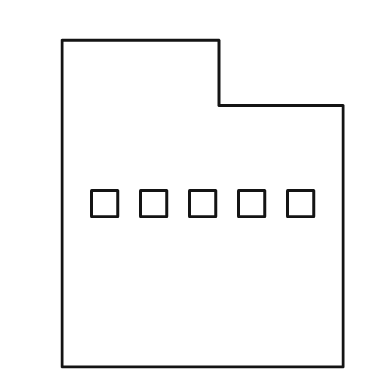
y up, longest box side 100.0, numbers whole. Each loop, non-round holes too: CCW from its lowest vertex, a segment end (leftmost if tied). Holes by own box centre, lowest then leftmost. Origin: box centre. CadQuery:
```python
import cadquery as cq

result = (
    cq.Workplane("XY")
    .moveTo(-43.0, -50.0)
    .lineTo(43.0, -50.0)
    .lineTo(43.0, 30.0)
    .lineTo(5.0, 30.0)
    .lineTo(5.0, 50.0)
    .lineTo(-43.0, 50.0)
    .close()
    .moveTo(-34.0, -4.0)
    .lineTo(-26.0, -4.0)
    .lineTo(-26.0, 4.0)
    .lineTo(-34.0, 4.0)
    .close()
    .moveTo(-19.0, -4.0)
    .lineTo(-11.0, -4.0)
    .lineTo(-11.0, 4.0)
    .lineTo(-19.0, 4.0)
    .close()
    .moveTo(-4.0, -4.0)
    .lineTo(4.0, -4.0)
    .lineTo(4.0, 4.0)
    .lineTo(-4.0, 4.0)
    .close()
    .moveTo(11.0, -4.0)
    .lineTo(19.0, -4.0)
    .lineTo(19.0, 4.0)
    .lineTo(11.0, 4.0)
    .close()
    .moveTo(26.0, -4.0)
    .lineTo(34.0, -4.0)
    .lineTo(34.0, 4.0)
    .lineTo(26.0, 4.0)
    .close()
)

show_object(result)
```